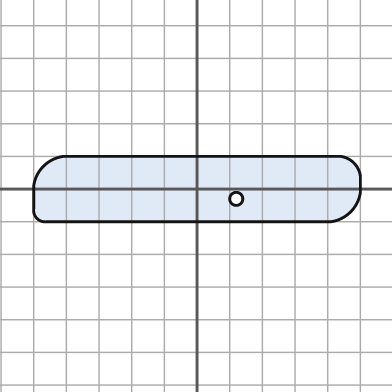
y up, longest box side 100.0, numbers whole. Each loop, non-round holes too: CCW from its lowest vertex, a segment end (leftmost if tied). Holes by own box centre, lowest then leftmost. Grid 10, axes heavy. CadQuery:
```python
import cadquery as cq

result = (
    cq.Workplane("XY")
    .moveTo(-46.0, -10.0)
    .lineTo(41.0, -10.0)
    .threePointArc((47.0, -7.0), (50.0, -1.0))
    .lineTo(50.0, 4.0)
    .threePointArc((48.0, 8.0), (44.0, 10.0))
    .lineTo(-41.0, 10.0)
    .threePointArc((-47.0, 7.0), (-50.0, 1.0))
    .lineTo(-50.0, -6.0)
    .threePointArc((-49.0, -9.0), (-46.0, -10.0))
    .close()
    .moveTo(12.0, -3.0)
    .circle(2.0)
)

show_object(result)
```